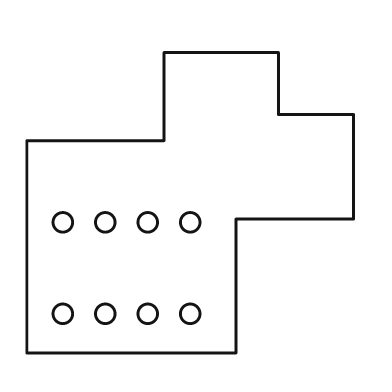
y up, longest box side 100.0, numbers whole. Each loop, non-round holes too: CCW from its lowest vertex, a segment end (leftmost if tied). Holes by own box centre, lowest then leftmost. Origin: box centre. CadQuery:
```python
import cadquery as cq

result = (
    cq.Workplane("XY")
    .moveTo(-50.0, -46.0)
    .lineTo(14.0, -46.0)
    .lineTo(14.0, -5.0)
    .lineTo(50.0, -5.0)
    .lineTo(50.0, 27.0)
    .lineTo(27.0, 27.0)
    .lineTo(27.0, 46.0)
    .lineTo(-8.0, 46.0)
    .lineTo(-8.0, 19.0)
    .lineTo(-50.0, 19.0)
    .close()
    .moveTo(-39.0, -34.0)
    .circle(3.0)
    .moveTo(-26.0, -34.0)
    .circle(3.0)
    .moveTo(-13.0, -34.0)
    .circle(3.0)
    .moveTo(0.0, -34.0)
    .circle(3.0)
    .moveTo(-39.0, -6.0)
    .circle(3.0)
    .moveTo(-26.0, -6.0)
    .circle(3.0)
    .moveTo(-13.0, -6.0)
    .circle(3.0)
    .moveTo(0.0, -6.0)
    .circle(3.0)
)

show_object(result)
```